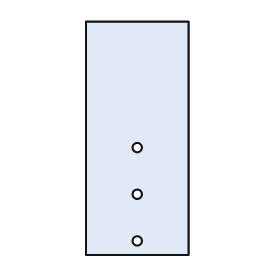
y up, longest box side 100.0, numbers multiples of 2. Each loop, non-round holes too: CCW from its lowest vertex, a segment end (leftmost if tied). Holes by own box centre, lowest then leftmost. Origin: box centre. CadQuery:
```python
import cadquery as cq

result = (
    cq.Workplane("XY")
    .moveTo(-22.0, -50.0)
    .lineTo(22.0, -50.0)
    .lineTo(22.0, 50.0)
    .lineTo(-22.0, 50.0)
    .close()
    .moveTo(0.0, -44.0)
    .circle(2.0)
    .moveTo(0.0, -24.0)
    .circle(2.0)
    .moveTo(0.0, -4.0)
    .circle(2.0)
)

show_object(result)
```